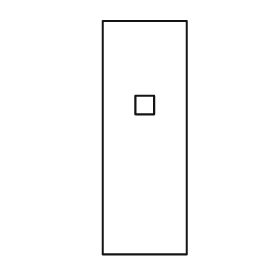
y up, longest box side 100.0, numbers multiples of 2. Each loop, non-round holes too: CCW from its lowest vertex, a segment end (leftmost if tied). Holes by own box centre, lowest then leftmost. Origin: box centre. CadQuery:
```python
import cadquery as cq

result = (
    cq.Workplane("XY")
    .moveTo(-18.0, -50.0)
    .lineTo(18.0, -50.0)
    .lineTo(18.0, 50.0)
    .lineTo(-18.0, 50.0)
    .close()
    .moveTo(-4.0, 10.0)
    .lineTo(4.0, 10.0)
    .lineTo(4.0, 18.0)
    .lineTo(-4.0, 18.0)
    .close()
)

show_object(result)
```